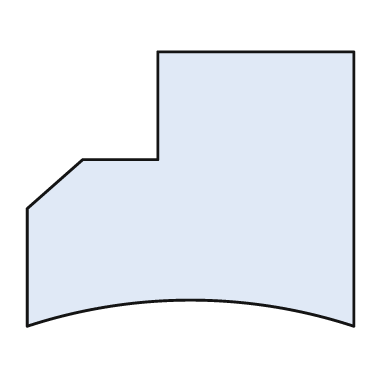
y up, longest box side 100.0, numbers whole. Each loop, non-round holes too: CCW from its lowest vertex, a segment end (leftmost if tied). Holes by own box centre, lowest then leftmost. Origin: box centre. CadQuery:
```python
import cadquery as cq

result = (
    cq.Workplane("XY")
    .moveTo(-50.0, -42.0)
    .threePointArc((0.0, -34.0), (50.0, -42.0))
    .lineTo(50.0, 42.0)
    .lineTo(-10.0, 42.0)
    .lineTo(-10.0, 9.0)
    .lineTo(-33.0, 9.0)
    .lineTo(-50.0, -6.0)
    .close()
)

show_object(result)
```